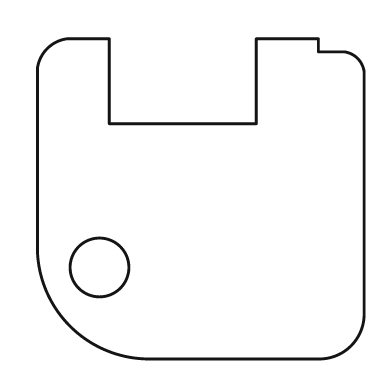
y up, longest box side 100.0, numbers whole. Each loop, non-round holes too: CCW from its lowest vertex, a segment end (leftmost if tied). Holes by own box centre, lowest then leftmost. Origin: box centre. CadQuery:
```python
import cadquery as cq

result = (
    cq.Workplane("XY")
    .moveTo(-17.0, -49.0)
    .lineTo(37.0, -49.0)
    .threePointArc((46.0, -45.0), (50.0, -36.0))
    .lineTo(50.0, 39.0)
    .threePointArc((48.0, 43.0), (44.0, 45.0))
    .lineTo(36.0, 45.0)
    .lineTo(36.0, 49.0)
    .lineTo(17.0, 49.0)
    .lineTo(17.0, 23.0)
    .lineTo(-28.0, 23.0)
    .lineTo(-28.0, 49.0)
    .lineTo(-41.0, 49.0)
    .threePointArc((-47.0, 46.0), (-50.0, 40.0))
    .lineTo(-50.0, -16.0)
    .threePointArc((-40.0, -39.0), (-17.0, -49.0))
    .close()
    .moveTo(-31.0, -21.0)
    .circle(9.0)
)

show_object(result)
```